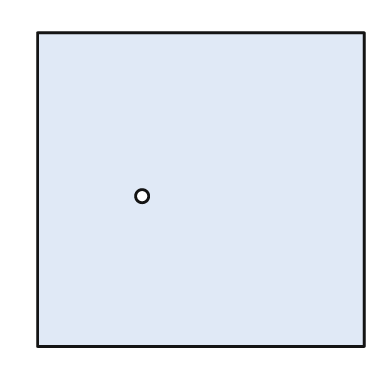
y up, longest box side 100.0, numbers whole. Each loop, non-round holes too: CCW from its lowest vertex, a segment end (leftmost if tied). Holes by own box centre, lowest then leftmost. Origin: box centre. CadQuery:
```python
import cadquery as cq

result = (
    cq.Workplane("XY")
    .moveTo(-50.0, -48.0)
    .lineTo(50.0, -48.0)
    .lineTo(50.0, 48.0)
    .lineTo(-50.0, 48.0)
    .close()
    .moveTo(-18.0, -2.0)
    .circle(2.0)
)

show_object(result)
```